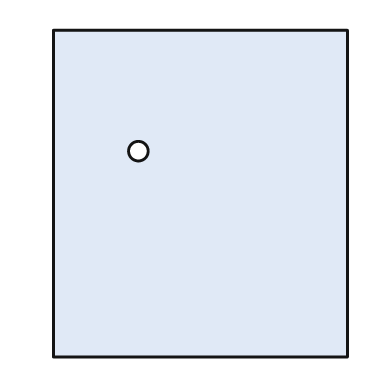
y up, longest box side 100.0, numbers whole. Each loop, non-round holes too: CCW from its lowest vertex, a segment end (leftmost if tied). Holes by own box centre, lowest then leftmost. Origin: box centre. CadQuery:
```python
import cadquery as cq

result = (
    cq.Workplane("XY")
    .moveTo(-45.0, -50.0)
    .lineTo(45.0, -50.0)
    .lineTo(45.0, 50.0)
    .lineTo(-45.0, 50.0)
    .close()
    .moveTo(-19.0, 13.0)
    .circle(3.0)
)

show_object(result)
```